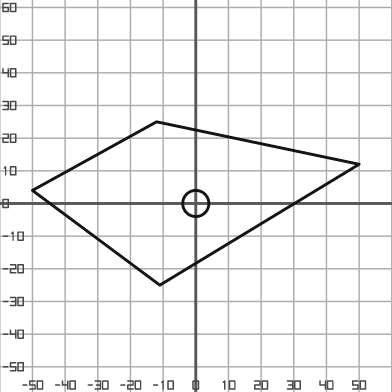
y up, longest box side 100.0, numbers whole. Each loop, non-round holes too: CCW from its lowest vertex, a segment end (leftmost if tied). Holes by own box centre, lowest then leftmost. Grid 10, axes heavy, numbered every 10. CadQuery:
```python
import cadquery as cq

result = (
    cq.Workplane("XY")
    .moveTo(-11.0, -25.0)
    .lineTo(50.0, 12.0)
    .lineTo(-12.0, 25.0)
    .lineTo(-50.0, 4.0)
    .close()
    .moveTo(0.0, 0.0)
    .circle(4.0)
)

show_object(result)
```